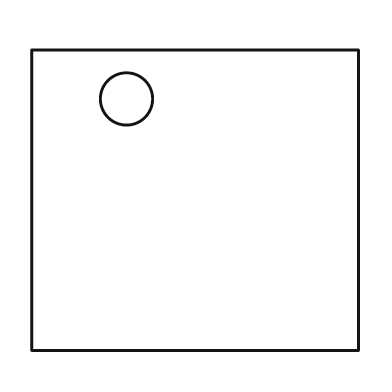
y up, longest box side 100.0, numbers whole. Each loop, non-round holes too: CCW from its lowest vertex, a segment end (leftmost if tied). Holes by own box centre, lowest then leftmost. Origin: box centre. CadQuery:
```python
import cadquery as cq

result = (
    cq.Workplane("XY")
    .moveTo(-50.0, -46.0)
    .lineTo(50.0, -46.0)
    .lineTo(50.0, 46.0)
    .lineTo(-50.0, 46.0)
    .close()
    .moveTo(-21.0, 31.0)
    .circle(8.0)
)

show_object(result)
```